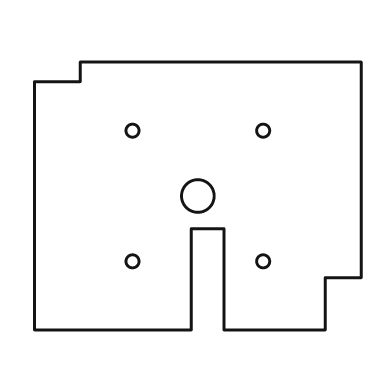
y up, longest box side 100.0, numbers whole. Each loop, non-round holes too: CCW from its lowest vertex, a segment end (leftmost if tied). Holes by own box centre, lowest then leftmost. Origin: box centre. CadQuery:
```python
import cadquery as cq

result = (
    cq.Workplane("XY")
    .moveTo(-50.0, -41.0)
    .lineTo(-2.0, -41.0)
    .lineTo(-2.0, -10.0)
    .lineTo(8.0, -10.0)
    .lineTo(8.0, -41.0)
    .lineTo(39.0, -41.0)
    .lineTo(39.0, -25.0)
    .lineTo(50.0, -25.0)
    .lineTo(50.0, 41.0)
    .lineTo(-36.0, 41.0)
    .lineTo(-36.0, 35.0)
    .lineTo(-50.0, 35.0)
    .close()
    .moveTo(-20.0, -20.0)
    .circle(2.0)
    .moveTo(20.0, -20.0)
    .circle(2.0)
    .moveTo(0.0, 0.0)
    .circle(5.0)
    .moveTo(-20.0, 20.0)
    .circle(2.0)
    .moveTo(20.0, 20.0)
    .circle(2.0)
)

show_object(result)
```